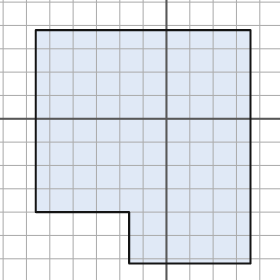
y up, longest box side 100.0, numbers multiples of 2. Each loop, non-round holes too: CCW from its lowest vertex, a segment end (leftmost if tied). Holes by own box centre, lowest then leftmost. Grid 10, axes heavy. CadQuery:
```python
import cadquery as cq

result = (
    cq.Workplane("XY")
    .moveTo(-16.0, -62.0)
    .lineTo(36.0, -62.0)
    .lineTo(36.0, 38.0)
    .lineTo(-56.0, 38.0)
    .lineTo(-56.0, -40.0)
    .lineTo(-16.0, -40.0)
    .close()
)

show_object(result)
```